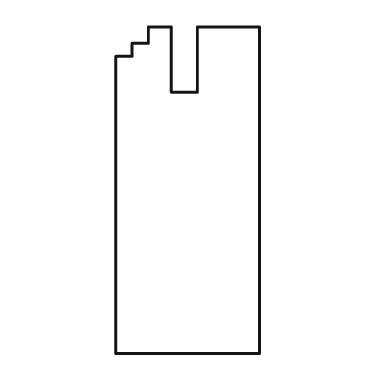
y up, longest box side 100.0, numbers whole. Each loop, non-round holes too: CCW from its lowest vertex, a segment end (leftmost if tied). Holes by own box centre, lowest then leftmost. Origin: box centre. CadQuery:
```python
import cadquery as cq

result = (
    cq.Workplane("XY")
    .moveTo(-22.0, -50.0)
    .lineTo(22.0, -50.0)
    .lineTo(22.0, 50.0)
    .lineTo(3.0, 50.0)
    .lineTo(3.0, 30.0)
    .lineTo(-5.0, 30.0)
    .lineTo(-5.0, 50.0)
    .lineTo(-12.0, 50.0)
    .lineTo(-12.0, 45.0)
    .lineTo(-17.0, 45.0)
    .lineTo(-17.0, 41.0)
    .lineTo(-22.0, 41.0)
    .close()
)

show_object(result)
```